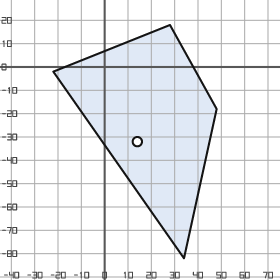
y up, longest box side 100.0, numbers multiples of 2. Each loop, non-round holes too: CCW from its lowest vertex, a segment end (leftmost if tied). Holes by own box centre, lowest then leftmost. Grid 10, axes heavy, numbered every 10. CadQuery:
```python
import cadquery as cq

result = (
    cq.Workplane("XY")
    .moveTo(34.0, -82.0)
    .lineTo(48.0, -18.0)
    .lineTo(28.0, 18.0)
    .lineTo(-22.0, -2.0)
    .close()
    .moveTo(14.0, -32.0)
    .circle(2.0)
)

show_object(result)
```